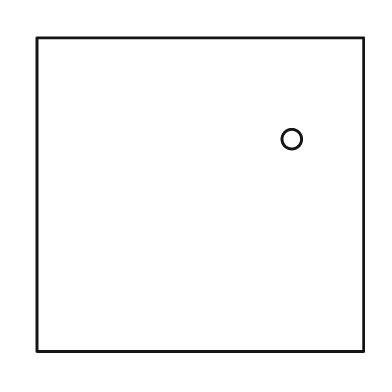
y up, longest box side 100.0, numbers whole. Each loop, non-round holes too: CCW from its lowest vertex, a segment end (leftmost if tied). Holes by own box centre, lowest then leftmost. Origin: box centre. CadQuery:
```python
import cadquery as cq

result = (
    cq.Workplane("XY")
    .moveTo(-50.0, -48.0)
    .lineTo(50.0, -48.0)
    .lineTo(50.0, 48.0)
    .lineTo(-50.0, 48.0)
    .close()
    .moveTo(28.0, 17.0)
    .circle(3.0)
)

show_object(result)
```